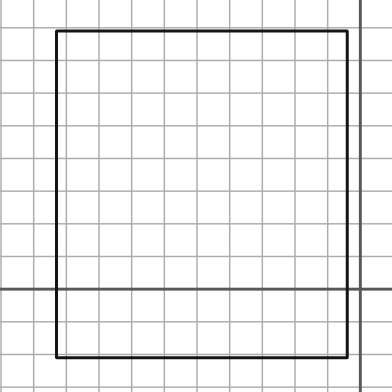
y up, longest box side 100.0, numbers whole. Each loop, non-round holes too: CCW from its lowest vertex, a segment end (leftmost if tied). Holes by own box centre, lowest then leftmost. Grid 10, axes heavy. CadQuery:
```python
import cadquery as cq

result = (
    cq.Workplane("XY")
    .moveTo(-93.0, -21.0)
    .lineTo(-4.0, -21.0)
    .lineTo(-4.0, 79.0)
    .lineTo(-93.0, 79.0)
    .close()
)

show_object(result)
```